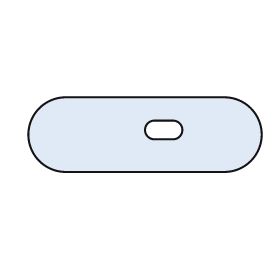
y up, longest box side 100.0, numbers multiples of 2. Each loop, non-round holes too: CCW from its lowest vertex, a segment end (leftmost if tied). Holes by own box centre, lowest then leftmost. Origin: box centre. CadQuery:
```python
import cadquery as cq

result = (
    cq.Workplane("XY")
    .moveTo(-34.0, -16.0)
    .lineTo(34.0, -16.0)
    .threePointArc((50.0, 0.0), (34.0, 16.0))
    .lineTo(-34.0, 16.0)
    .threePointArc((-50.0, 0.0), (-34.0, -16.0))
    .close()
    .moveTo(4.0, -2.0)
    .lineTo(12.0, -2.0)
    .threePointArc((16.0, 2.0), (12.0, 6.0))
    .lineTo(4.0, 6.0)
    .threePointArc((0.0, 2.0), (4.0, -2.0))
    .close()
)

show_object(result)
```